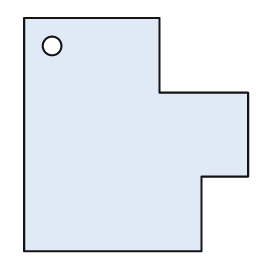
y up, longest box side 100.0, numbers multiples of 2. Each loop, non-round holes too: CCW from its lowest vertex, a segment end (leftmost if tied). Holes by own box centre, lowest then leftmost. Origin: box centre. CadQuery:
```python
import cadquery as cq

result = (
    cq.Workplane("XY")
    .moveTo(-48.0, -50.0)
    .lineTo(28.0, -50.0)
    .lineTo(28.0, -18.0)
    .lineTo(48.0, -18.0)
    .lineTo(48.0, 18.0)
    .lineTo(10.0, 18.0)
    .lineTo(10.0, 50.0)
    .lineTo(-48.0, 50.0)
    .close()
    .moveTo(-36.0, 38.0)
    .circle(4.0)
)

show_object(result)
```